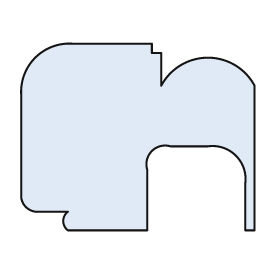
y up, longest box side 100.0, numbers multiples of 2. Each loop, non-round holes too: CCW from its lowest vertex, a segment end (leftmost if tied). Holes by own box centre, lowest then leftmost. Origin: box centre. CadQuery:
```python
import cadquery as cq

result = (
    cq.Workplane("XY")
    .moveTo(-30.0, -40.0)
    .lineTo(4.0, -40.0)
    .lineTo(4.0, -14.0)
    .threePointArc((6.0, -6.0), (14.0, -4.0))
    .lineTo(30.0, -4.0)
    .threePointArc((42.0, -8.0), (46.0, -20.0))
    .lineTo(46.0, -40.0)
    .lineTo(50.0, -40.0)
    .lineTo(50.0, 22.0)
    .threePointArc((30.0, 34.0), (10.0, 22.0))
    .lineTo(10.0, 36.0)
    .lineTo(6.0, 36.0)
    .lineTo(6.0, 40.0)
    .lineTo(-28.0, 40.0)
    .threePointArc((-44.0, 34.0), (-50.0, 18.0))
    .lineTo(-50.0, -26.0)
    .threePointArc((-48.0, -30.0), (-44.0, -32.0))
    .lineTo(-30.0, -32.0)
    .threePointArc((-32.0, -36.0), (-30.0, -40.0))
    .close()
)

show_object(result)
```